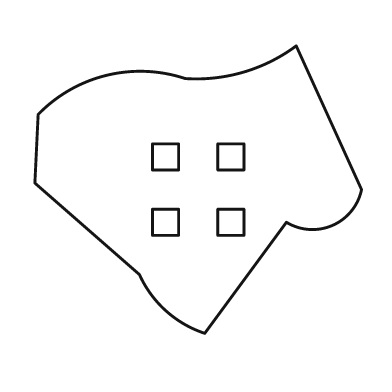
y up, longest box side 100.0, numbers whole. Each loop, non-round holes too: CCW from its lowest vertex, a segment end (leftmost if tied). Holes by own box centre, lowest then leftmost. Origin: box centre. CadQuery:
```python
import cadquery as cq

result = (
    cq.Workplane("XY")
    .moveTo(2.0, -44.0)
    .lineTo(27.0, -10.0)
    .threePointArc((41.0, -11.0), (50.0, 0.0))
    .lineTo(30.0, 44.0)
    .threePointArc((14.0, 36.0), (-4.0, 34.0))
    .threePointArc((-28.0, 35.0), (-49.0, 23.0))
    .lineTo(-50.0, 2.0)
    .lineTo(-18.0, -26.0)
    .threePointArc((-10.0, -37.0), (2.0, -44.0))
    .close()
    .moveTo(-14.0, -14.0)
    .lineTo(-6.0, -14.0)
    .lineTo(-6.0, -6.0)
    .lineTo(-14.0, -6.0)
    .close()
    .moveTo(6.0, -14.0)
    .lineTo(14.0, -14.0)
    .lineTo(14.0, -6.0)
    .lineTo(6.0, -6.0)
    .close()
    .moveTo(-14.0, 6.0)
    .lineTo(-6.0, 6.0)
    .lineTo(-6.0, 14.0)
    .lineTo(-14.0, 14.0)
    .close()
    .moveTo(6.0, 6.0)
    .lineTo(14.0, 6.0)
    .lineTo(14.0, 14.0)
    .lineTo(6.0, 14.0)
    .close()
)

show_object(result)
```